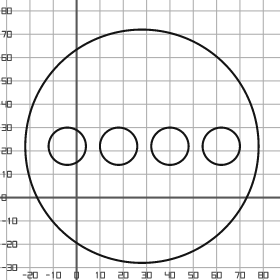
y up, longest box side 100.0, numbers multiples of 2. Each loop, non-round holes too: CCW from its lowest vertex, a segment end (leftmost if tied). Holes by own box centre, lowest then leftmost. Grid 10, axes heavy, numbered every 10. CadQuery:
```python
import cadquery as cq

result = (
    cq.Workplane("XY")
    .moveTo(28.0, 22.0)
    .circle(50.0)
    .moveTo(-4.0, 22.0)
    .circle(8.0)
    .moveTo(18.0, 22.0)
    .circle(8.0)
    .moveTo(40.0, 22.0)
    .circle(8.0)
    .moveTo(62.0, 22.0)
    .circle(8.0)
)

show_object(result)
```